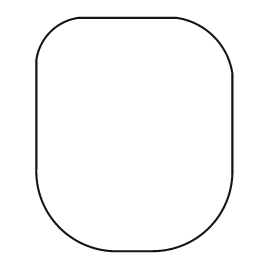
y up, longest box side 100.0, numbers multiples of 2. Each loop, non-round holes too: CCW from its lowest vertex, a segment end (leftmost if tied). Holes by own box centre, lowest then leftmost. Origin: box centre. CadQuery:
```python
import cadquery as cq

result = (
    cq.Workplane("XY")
    .moveTo(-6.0, -50.0)
    .lineTo(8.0, -50.0)
    .threePointArc((32.0, -40.0), (42.0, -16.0))
    .lineTo(42.0, 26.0)
    .threePointArc((34.0, 42.0), (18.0, 50.0))
    .lineTo(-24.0, 50.0)
    .threePointArc((-36.0, 44.0), (-42.0, 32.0))
    .lineTo(-42.0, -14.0)
    .threePointArc((-32.0, -40.0), (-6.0, -50.0))
    .close()
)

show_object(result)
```